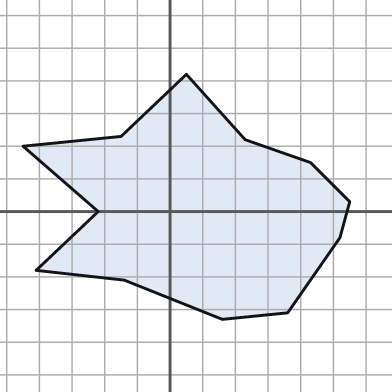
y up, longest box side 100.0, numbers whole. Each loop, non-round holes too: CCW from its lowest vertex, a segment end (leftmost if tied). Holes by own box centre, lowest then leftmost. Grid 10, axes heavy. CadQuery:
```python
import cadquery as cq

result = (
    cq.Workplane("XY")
    .moveTo(16.0, -33.0)
    .lineTo(36.0, -31.0)
    .lineTo(52.0, -8.0)
    .lineTo(55.0, 3.0)
    .lineTo(43.0, 15.0)
    .lineTo(23.0, 22.0)
    .lineTo(5.0, 42.0)
    .lineTo(-15.0, 23.0)
    .lineTo(-45.0, 20.0)
    .lineTo(-22.0, 0.0)
    .lineTo(-41.0, -18.0)
    .lineTo(-14.0, -21.0)
    .close()
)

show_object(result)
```